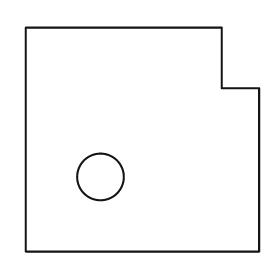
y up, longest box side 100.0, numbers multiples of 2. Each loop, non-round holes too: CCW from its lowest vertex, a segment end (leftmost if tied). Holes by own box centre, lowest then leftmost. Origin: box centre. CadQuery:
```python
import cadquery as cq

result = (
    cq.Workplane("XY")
    .moveTo(-50.0, -48.0)
    .lineTo(50.0, -48.0)
    .lineTo(50.0, 22.0)
    .lineTo(34.0, 22.0)
    .lineTo(34.0, 48.0)
    .lineTo(-50.0, 48.0)
    .close()
    .moveTo(-18.0, -16.0)
    .circle(10.0)
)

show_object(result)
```